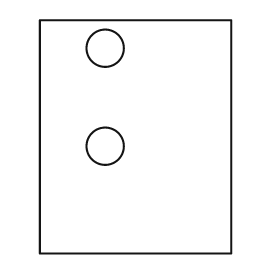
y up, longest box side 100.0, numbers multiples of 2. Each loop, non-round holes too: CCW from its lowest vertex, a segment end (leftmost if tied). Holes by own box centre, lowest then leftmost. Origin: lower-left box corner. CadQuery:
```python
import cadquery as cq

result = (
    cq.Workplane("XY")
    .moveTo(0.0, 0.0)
    .lineTo(82.0, 0.0)
    .lineTo(82.0, 100.0)
    .lineTo(0.0, 100.0)
    .close()
    .moveTo(28.0, 46.0)
    .circle(8.0)
    .moveTo(28.0, 88.0)
    .circle(8.0)
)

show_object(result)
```